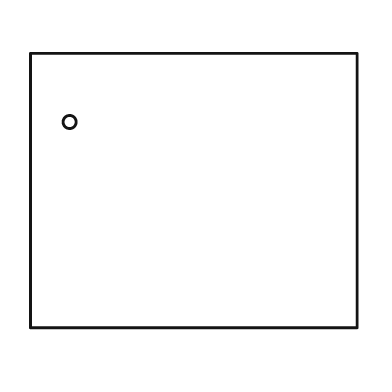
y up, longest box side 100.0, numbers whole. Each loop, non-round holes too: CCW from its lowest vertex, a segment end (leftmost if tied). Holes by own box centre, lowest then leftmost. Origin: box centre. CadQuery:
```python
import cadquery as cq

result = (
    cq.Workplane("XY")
    .moveTo(-50.0, -42.0)
    .lineTo(50.0, -42.0)
    .lineTo(50.0, 42.0)
    .lineTo(-50.0, 42.0)
    .close()
    .moveTo(-38.0, 21.0)
    .circle(2.0)
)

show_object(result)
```